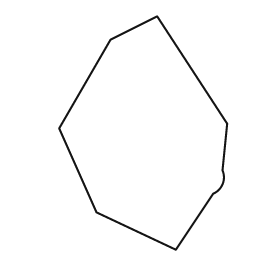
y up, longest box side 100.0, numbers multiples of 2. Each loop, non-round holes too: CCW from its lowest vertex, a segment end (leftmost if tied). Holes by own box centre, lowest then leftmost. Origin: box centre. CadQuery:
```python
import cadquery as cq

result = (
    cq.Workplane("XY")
    .moveTo(14.0, -50.0)
    .lineTo(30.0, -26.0)
    .threePointArc((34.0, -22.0), (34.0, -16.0))
    .lineTo(36.0, 4.0)
    .lineTo(6.0, 50.0)
    .lineTo(-14.0, 40.0)
    .lineTo(-36.0, 2.0)
    .lineTo(-20.0, -34.0)
    .close()
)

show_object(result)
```